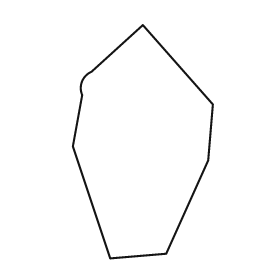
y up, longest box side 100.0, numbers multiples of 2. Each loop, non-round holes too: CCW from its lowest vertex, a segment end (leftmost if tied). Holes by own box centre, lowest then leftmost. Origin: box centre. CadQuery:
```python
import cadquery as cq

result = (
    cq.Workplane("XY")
    .moveTo(-14.0, -50.0)
    .lineTo(10.0, -48.0)
    .lineTo(28.0, -8.0)
    .lineTo(30.0, 16.0)
    .lineTo(0.0, 50.0)
    .lineTo(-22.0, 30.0)
    .threePointArc((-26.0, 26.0), (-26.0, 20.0))
    .lineTo(-30.0, -2.0)
    .close()
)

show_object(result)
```